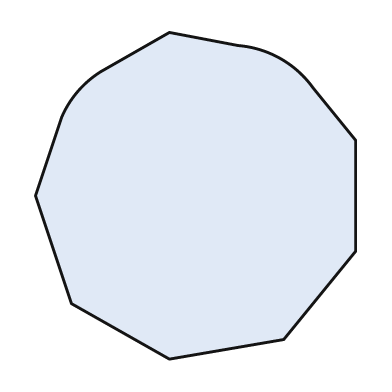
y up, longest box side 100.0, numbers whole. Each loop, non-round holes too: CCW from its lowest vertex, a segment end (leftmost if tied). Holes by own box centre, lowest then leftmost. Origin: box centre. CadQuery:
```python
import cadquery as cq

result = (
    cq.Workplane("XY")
    .moveTo(-8.0, -50.0)
    .lineTo(27.0, -44.0)
    .lineTo(49.0, -17.0)
    .lineTo(49.0, 17.0)
    .lineTo(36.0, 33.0)
    .threePointArc((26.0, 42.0), (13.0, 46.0))
    .lineTo(-8.0, 50.0)
    .lineTo(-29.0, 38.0)
    .threePointArc((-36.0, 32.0), (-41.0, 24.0))
    .lineTo(-49.0, 0.0)
    .lineTo(-38.0, -33.0)
    .close()
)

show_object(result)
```